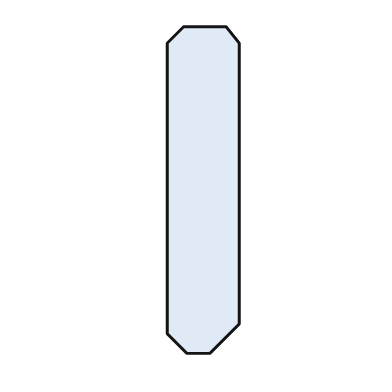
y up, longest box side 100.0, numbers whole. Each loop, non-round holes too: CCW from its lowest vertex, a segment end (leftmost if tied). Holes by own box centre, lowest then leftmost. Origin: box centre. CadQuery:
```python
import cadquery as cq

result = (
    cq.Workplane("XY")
    .moveTo(-5.0, -50.0)
    .lineTo(2.0, -50.0)
    .lineTo(11.0, -41.0)
    .lineTo(11.0, 45.0)
    .lineTo(7.0, 50.0)
    .lineTo(-6.0, 50.0)
    .lineTo(-11.0, 45.0)
    .lineTo(-11.0, -44.0)
    .close()
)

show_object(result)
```